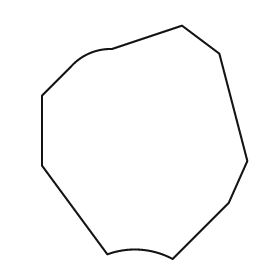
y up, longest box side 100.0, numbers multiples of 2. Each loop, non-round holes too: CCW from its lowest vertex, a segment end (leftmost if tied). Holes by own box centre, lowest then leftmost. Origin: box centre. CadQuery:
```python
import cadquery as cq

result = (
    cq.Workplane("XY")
    .moveTo(12.0, -50.0)
    .lineTo(36.0, -26.0)
    .lineTo(44.0, -8.0)
    .lineTo(32.0, 38.0)
    .lineTo(16.0, 50.0)
    .lineTo(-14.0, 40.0)
    .threePointArc((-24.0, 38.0), (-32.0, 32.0))
    .lineTo(-44.0, 20.0)
    .lineTo(-44.0, -10.0)
    .lineTo(-16.0, -48.0)
    .threePointArc((-2.0, -46.0), (12.0, -50.0))
    .close()
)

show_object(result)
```